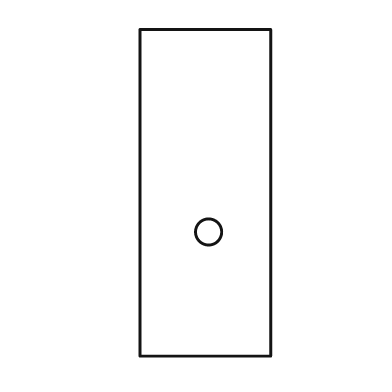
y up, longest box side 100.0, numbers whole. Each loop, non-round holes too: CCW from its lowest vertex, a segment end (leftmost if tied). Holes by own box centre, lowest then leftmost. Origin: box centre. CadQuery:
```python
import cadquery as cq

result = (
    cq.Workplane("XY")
    .moveTo(-20.0, -50.0)
    .lineTo(20.0, -50.0)
    .lineTo(20.0, 50.0)
    .lineTo(-20.0, 50.0)
    .close()
    .moveTo(1.0, -12.0)
    .circle(4.0)
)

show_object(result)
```